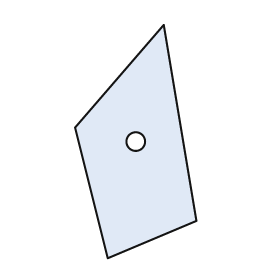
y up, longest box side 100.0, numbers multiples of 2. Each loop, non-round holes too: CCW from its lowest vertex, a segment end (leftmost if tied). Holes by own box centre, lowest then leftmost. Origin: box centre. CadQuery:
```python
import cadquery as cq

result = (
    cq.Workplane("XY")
    .moveTo(-12.0, -50.0)
    .lineTo(26.0, -34.0)
    .lineTo(12.0, 50.0)
    .lineTo(-26.0, 6.0)
    .close()
    .moveTo(0.0, 0.0)
    .circle(4.0)
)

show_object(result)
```